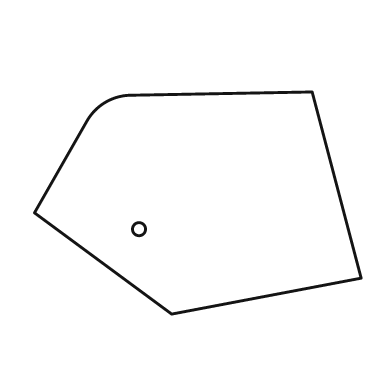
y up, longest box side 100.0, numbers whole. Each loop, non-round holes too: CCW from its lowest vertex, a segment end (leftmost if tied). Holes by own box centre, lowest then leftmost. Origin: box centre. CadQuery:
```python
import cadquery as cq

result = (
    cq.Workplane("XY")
    .moveTo(-8.0, -34.0)
    .lineTo(50.0, -23.0)
    .lineTo(35.0, 34.0)
    .lineTo(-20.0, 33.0)
    .threePointArc((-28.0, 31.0), (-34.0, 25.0))
    .lineTo(-50.0, -3.0)
    .close()
    .moveTo(-18.0, -8.0)
    .circle(2.0)
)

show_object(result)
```